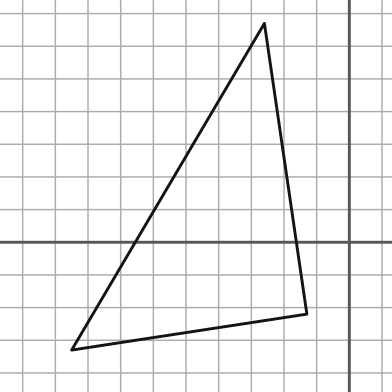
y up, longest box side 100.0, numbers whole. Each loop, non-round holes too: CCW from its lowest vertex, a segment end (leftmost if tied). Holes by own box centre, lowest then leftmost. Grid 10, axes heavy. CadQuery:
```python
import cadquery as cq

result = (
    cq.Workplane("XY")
    .moveTo(-85.0, -33.0)
    .lineTo(-13.0, -22.0)
    .lineTo(-26.0, 67.0)
    .close()
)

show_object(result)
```